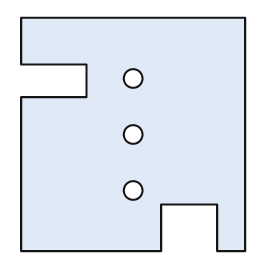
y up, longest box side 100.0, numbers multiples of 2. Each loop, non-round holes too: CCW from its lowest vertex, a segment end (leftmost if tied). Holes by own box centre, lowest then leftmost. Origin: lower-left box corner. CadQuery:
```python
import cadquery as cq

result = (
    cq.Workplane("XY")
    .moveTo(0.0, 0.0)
    .lineTo(60.0, 0.0)
    .lineTo(60.0, 20.0)
    .lineTo(84.0, 20.0)
    .lineTo(84.0, 0.0)
    .lineTo(96.0, 0.0)
    .lineTo(96.0, 100.0)
    .lineTo(0.0, 100.0)
    .lineTo(0.0, 80.0)
    .lineTo(28.0, 80.0)
    .lineTo(28.0, 66.0)
    .lineTo(0.0, 66.0)
    .close()
    .moveTo(48.0, 26.0)
    .circle(4.0)
    .moveTo(48.0, 50.0)
    .circle(4.0)
    .moveTo(48.0, 74.0)
    .circle(4.0)
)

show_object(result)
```